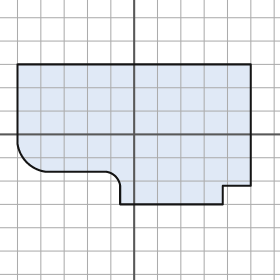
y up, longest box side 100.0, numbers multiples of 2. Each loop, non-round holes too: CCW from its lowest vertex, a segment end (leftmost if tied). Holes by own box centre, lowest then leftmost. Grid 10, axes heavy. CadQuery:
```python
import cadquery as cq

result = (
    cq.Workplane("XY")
    .moveTo(-6.0, -30.0)
    .lineTo(38.0, -30.0)
    .lineTo(38.0, -22.0)
    .lineTo(50.0, -22.0)
    .lineTo(50.0, 30.0)
    .lineTo(-50.0, 30.0)
    .lineTo(-50.0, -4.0)
    .threePointArc((-46.0, -12.0), (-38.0, -16.0))
    .lineTo(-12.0, -16.0)
    .threePointArc((-8.0, -18.0), (-6.0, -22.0))
    .close()
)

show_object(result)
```